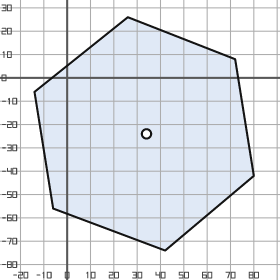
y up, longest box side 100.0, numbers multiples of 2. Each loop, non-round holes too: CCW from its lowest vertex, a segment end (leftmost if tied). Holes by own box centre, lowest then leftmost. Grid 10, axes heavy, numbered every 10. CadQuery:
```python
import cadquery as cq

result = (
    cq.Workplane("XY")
    .moveTo(42.0, -74.0)
    .lineTo(80.0, -42.0)
    .lineTo(72.0, 8.0)
    .lineTo(26.0, 26.0)
    .lineTo(-14.0, -6.0)
    .lineTo(-6.0, -56.0)
    .close()
    .moveTo(34.0, -24.0)
    .circle(2.0)
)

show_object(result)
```